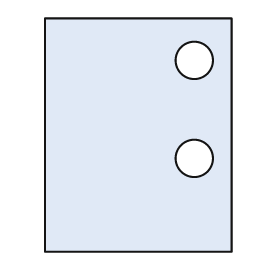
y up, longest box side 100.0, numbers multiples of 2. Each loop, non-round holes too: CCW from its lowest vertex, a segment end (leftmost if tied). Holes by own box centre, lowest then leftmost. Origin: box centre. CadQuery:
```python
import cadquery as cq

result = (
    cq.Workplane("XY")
    .moveTo(-40.0, -50.0)
    .lineTo(40.0, -50.0)
    .lineTo(40.0, 50.0)
    .lineTo(-40.0, 50.0)
    .close()
    .moveTo(24.0, -10.0)
    .circle(8.0)
    .moveTo(24.0, 32.0)
    .circle(8.0)
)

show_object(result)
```